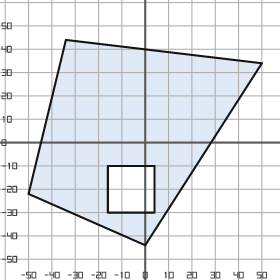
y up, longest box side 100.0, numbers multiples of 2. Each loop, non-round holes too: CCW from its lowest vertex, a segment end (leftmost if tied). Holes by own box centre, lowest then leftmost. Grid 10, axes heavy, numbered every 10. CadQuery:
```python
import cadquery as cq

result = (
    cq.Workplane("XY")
    .moveTo(0.0, -44.0)
    .lineTo(50.0, 34.0)
    .lineTo(-34.0, 44.0)
    .lineTo(-50.0, -22.0)
    .close()
    .moveTo(-16.0, -30.0)
    .lineTo(4.0, -30.0)
    .lineTo(4.0, -10.0)
    .lineTo(-16.0, -10.0)
    .close()
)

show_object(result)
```